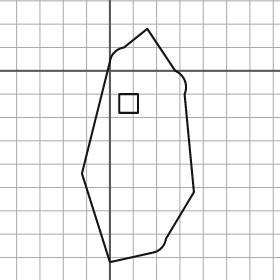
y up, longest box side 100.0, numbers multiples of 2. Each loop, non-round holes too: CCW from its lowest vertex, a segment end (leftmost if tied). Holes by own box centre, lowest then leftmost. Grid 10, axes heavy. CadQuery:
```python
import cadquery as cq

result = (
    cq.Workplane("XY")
    .moveTo(0.0, -82.0)
    .lineTo(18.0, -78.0)
    .threePointArc((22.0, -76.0), (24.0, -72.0))
    .lineTo(36.0, -52.0)
    .lineTo(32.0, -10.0)
    .threePointArc((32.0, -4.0), (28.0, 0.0))
    .lineTo(16.0, 18.0)
    .lineTo(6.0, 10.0)
    .threePointArc((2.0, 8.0), (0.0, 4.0))
    .lineTo(-12.0, -44.0)
    .close()
    .moveTo(4.0, -18.0)
    .lineTo(12.0, -18.0)
    .lineTo(12.0, -10.0)
    .lineTo(4.0, -10.0)
    .close()
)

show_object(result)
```